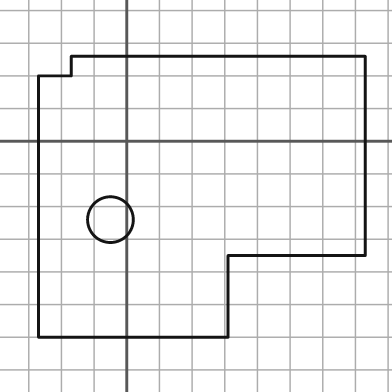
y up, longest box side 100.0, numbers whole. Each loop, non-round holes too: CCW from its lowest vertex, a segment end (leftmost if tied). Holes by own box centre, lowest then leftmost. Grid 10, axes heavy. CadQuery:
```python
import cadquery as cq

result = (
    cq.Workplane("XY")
    .moveTo(-27.0, -60.0)
    .lineTo(31.0, -60.0)
    .lineTo(31.0, -35.0)
    .lineTo(73.0, -35.0)
    .lineTo(73.0, 26.0)
    .lineTo(-17.0, 26.0)
    .lineTo(-17.0, 20.0)
    .lineTo(-27.0, 20.0)
    .close()
    .moveTo(-5.0, -24.0)
    .circle(7.0)
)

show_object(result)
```